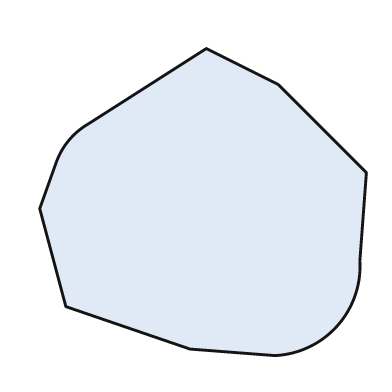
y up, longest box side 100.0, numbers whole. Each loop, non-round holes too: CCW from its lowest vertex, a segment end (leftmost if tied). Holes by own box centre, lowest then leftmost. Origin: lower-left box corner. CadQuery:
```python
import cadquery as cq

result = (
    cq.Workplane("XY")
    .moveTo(72.0, 0.0)
    .threePointArc((91.0, 9.0), (98.0, 29.0))
    .lineTo(100.0, 56.0)
    .lineTo(73.0, 83.0)
    .lineTo(51.0, 94.0)
    .lineTo(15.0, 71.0)
    .threePointArc((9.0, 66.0), (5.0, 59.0))
    .lineTo(0.0, 45.0)
    .lineTo(8.0, 15.0)
    .lineTo(46.0, 2.0)
    .close()
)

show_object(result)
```